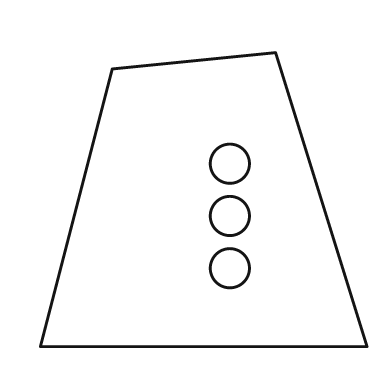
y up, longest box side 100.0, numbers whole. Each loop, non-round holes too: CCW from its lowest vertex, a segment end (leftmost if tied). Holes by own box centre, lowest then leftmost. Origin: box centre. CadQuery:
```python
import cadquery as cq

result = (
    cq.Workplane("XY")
    .moveTo(-50.0, -45.0)
    .lineTo(50.0, -45.0)
    .lineTo(22.0, 45.0)
    .lineTo(-28.0, 40.0)
    .close()
    .moveTo(8.0, -21.0)
    .circle(6.0)
    .moveTo(8.0, -5.0)
    .circle(6.0)
    .moveTo(8.0, 11.0)
    .circle(6.0)
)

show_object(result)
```